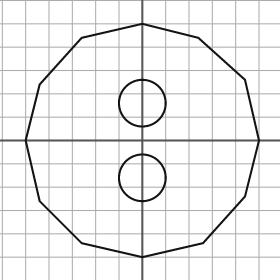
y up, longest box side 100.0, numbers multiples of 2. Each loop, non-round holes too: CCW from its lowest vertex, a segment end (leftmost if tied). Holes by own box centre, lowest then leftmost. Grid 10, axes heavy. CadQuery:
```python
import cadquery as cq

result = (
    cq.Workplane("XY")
    .moveTo(0.0, -50.0)
    .lineTo(26.0, -44.0)
    .lineTo(44.0, -24.0)
    .lineTo(50.0, 0.0)
    .lineTo(44.0, 26.0)
    .lineTo(24.0, 44.0)
    .lineTo(0.0, 50.0)
    .lineTo(-26.0, 44.0)
    .lineTo(-44.0, 24.0)
    .lineTo(-50.0, 0.0)
    .lineTo(-44.0, -26.0)
    .lineTo(-26.0, -44.0)
    .close()
    .moveTo(0.0, -16.0)
    .circle(10.0)
    .moveTo(0.0, 16.0)
    .circle(10.0)
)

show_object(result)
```